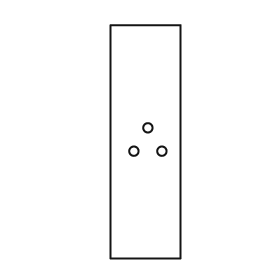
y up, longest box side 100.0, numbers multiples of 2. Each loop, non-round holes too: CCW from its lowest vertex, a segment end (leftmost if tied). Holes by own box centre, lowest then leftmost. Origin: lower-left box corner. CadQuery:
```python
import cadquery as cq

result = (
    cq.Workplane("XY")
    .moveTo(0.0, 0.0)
    .lineTo(30.0, 0.0)
    .lineTo(30.0, 100.0)
    .lineTo(0.0, 100.0)
    .close()
    .moveTo(10.0, 46.0)
    .circle(2.0)
    .moveTo(22.0, 46.0)
    .circle(2.0)
    .moveTo(16.0, 56.0)
    .circle(2.0)
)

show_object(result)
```